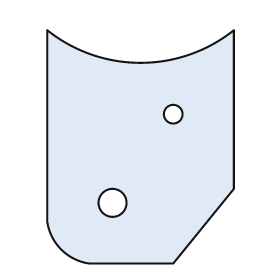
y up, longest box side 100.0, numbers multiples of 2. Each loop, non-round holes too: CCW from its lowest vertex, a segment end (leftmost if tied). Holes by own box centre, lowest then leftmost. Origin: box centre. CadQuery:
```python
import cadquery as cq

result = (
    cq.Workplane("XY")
    .moveTo(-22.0, -50.0)
    .lineTo(14.0, -50.0)
    .lineTo(40.0, -18.0)
    .lineTo(40.0, 50.0)
    .threePointArc((0.0, 36.0), (-40.0, 50.0))
    .lineTo(-40.0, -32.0)
    .threePointArc((-34.0, -44.0), (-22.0, -50.0))
    .close()
    .moveTo(-12.0, -24.0)
    .circle(6.0)
    .moveTo(14.0, 14.0)
    .circle(4.0)
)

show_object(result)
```